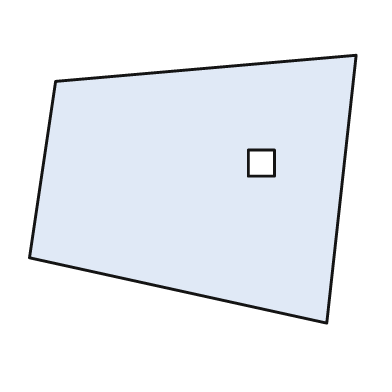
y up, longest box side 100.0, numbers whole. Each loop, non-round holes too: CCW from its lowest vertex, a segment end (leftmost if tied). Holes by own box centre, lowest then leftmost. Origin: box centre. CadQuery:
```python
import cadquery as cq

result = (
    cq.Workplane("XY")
    .moveTo(41.0, -41.0)
    .lineTo(50.0, 41.0)
    .lineTo(-42.0, 33.0)
    .lineTo(-50.0, -21.0)
    .close()
    .moveTo(17.0, 4.0)
    .lineTo(25.0, 4.0)
    .lineTo(25.0, 12.0)
    .lineTo(17.0, 12.0)
    .close()
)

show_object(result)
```